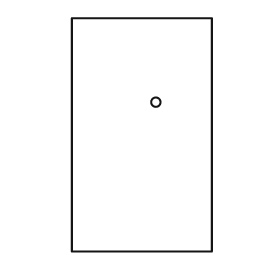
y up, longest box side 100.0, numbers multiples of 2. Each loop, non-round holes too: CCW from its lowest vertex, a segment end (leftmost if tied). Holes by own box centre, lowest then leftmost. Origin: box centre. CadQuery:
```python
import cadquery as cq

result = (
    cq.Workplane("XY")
    .moveTo(-30.0, -50.0)
    .lineTo(30.0, -50.0)
    .lineTo(30.0, 50.0)
    .lineTo(-30.0, 50.0)
    .close()
    .moveTo(6.0, 14.0)
    .circle(2.0)
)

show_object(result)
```